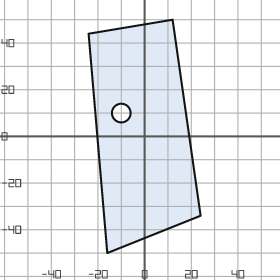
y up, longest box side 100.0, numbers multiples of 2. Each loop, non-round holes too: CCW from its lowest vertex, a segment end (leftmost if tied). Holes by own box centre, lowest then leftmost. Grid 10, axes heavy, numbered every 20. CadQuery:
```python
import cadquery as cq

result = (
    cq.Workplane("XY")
    .moveTo(-16.0, -50.0)
    .lineTo(24.0, -34.0)
    .lineTo(12.0, 50.0)
    .lineTo(-24.0, 44.0)
    .close()
    .moveTo(-10.0, 10.0)
    .circle(4.0)
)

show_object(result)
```